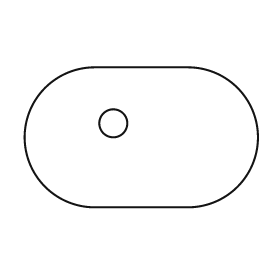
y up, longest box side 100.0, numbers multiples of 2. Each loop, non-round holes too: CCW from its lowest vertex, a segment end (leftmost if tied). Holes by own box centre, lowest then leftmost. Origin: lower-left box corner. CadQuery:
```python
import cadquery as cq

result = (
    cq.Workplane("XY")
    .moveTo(30.0, 0.0)
    .lineTo(70.0, 0.0)
    .threePointArc((100.0, 30.0), (70.0, 60.0))
    .lineTo(30.0, 60.0)
    .threePointArc((0.0, 30.0), (30.0, 0.0))
    .close()
    .moveTo(38.0, 36.0)
    .circle(6.0)
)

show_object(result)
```